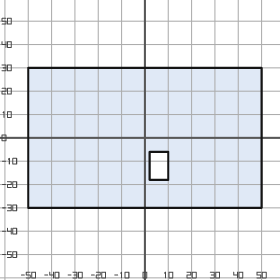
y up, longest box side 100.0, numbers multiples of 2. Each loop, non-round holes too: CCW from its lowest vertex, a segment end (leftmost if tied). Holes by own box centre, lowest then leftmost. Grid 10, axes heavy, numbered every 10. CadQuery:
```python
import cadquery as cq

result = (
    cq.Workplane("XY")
    .moveTo(-50.0, -30.0)
    .lineTo(50.0, -30.0)
    .lineTo(50.0, 30.0)
    .lineTo(-50.0, 30.0)
    .close()
    .moveTo(2.0, -18.0)
    .lineTo(10.0, -18.0)
    .lineTo(10.0, -6.0)
    .lineTo(2.0, -6.0)
    .close()
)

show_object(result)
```